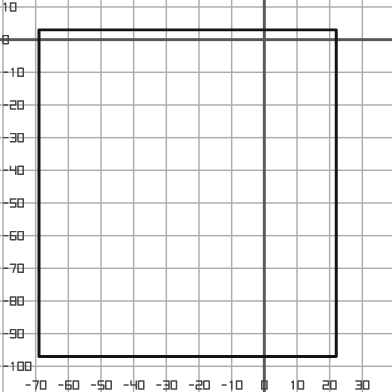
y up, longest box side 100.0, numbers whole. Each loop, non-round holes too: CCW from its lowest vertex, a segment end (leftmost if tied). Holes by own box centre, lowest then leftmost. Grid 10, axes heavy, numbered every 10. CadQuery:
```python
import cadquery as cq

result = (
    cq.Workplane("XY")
    .moveTo(-69.0, -97.0)
    .lineTo(22.0, -97.0)
    .lineTo(22.0, 3.0)
    .lineTo(-69.0, 3.0)
    .close()
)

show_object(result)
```